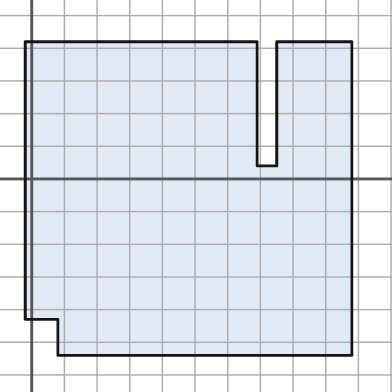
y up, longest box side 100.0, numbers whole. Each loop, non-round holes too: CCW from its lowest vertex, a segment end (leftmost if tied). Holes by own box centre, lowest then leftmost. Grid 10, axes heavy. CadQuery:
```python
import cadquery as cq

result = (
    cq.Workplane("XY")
    .moveTo(8.0, -54.0)
    .lineTo(98.0, -54.0)
    .lineTo(98.0, 42.0)
    .lineTo(75.0, 42.0)
    .lineTo(75.0, 4.0)
    .lineTo(69.0, 4.0)
    .lineTo(69.0, 42.0)
    .lineTo(-2.0, 42.0)
    .lineTo(-2.0, -43.0)
    .lineTo(8.0, -43.0)
    .close()
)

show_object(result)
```